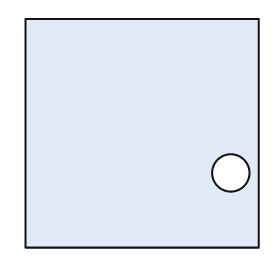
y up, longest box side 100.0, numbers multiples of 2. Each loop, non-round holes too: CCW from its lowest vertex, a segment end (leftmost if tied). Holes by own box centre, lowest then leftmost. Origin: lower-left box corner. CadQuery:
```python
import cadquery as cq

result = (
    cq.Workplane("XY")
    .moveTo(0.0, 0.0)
    .lineTo(100.0, 0.0)
    .lineTo(100.0, 98.0)
    .lineTo(0.0, 98.0)
    .close()
    .moveTo(88.0, 32.0)
    .circle(8.0)
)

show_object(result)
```